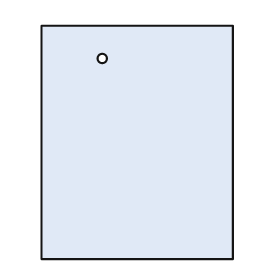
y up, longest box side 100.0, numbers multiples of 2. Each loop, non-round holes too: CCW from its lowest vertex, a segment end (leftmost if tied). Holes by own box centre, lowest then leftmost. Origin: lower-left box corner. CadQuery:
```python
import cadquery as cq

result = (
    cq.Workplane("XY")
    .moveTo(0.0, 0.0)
    .lineTo(82.0, 0.0)
    .lineTo(82.0, 100.0)
    .lineTo(0.0, 100.0)
    .close()
    .moveTo(26.0, 86.0)
    .circle(2.0)
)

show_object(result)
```